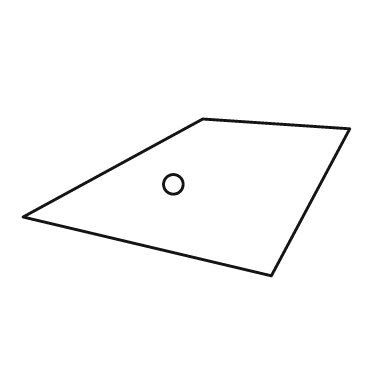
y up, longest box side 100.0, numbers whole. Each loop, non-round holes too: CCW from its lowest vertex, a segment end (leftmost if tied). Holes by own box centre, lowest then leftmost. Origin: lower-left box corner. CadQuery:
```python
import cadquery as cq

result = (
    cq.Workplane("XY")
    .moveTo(76.0, 0.0)
    .lineTo(100.0, 45.0)
    .lineTo(55.0, 48.0)
    .lineTo(0.0, 18.0)
    .close()
    .moveTo(46.0, 28.0)
    .circle(3.0)
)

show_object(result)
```